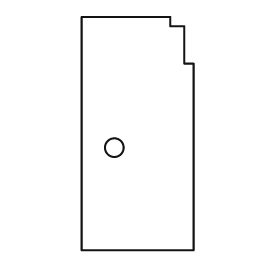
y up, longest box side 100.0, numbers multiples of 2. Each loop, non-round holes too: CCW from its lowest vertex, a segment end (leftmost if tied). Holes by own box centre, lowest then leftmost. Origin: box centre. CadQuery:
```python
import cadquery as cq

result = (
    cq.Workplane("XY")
    .moveTo(-24.0, -50.0)
    .lineTo(24.0, -50.0)
    .lineTo(24.0, 30.0)
    .lineTo(20.0, 30.0)
    .lineTo(20.0, 46.0)
    .lineTo(14.0, 46.0)
    .lineTo(14.0, 50.0)
    .lineTo(-24.0, 50.0)
    .close()
    .moveTo(-10.0, -6.0)
    .circle(4.0)
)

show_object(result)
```